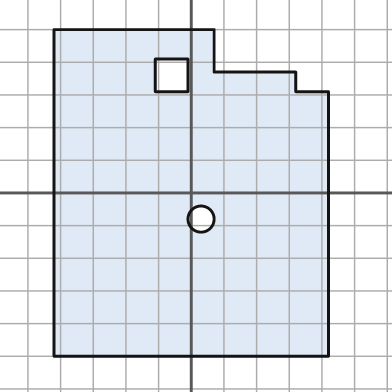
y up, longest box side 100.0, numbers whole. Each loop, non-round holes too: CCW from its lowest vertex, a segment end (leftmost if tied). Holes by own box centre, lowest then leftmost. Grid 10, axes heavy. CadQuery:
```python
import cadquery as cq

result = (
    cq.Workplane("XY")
    .moveTo(-42.0, -50.0)
    .lineTo(42.0, -50.0)
    .lineTo(42.0, 31.0)
    .lineTo(32.0, 31.0)
    .lineTo(32.0, 37.0)
    .lineTo(7.0, 37.0)
    .lineTo(7.0, 50.0)
    .lineTo(-42.0, 50.0)
    .close()
    .moveTo(3.0, -8.0)
    .circle(4.0)
    .moveTo(-11.0, 31.0)
    .lineTo(-1.0, 31.0)
    .lineTo(-1.0, 41.0)
    .lineTo(-11.0, 41.0)
    .close()
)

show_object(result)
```